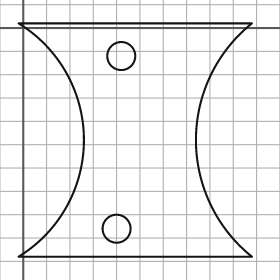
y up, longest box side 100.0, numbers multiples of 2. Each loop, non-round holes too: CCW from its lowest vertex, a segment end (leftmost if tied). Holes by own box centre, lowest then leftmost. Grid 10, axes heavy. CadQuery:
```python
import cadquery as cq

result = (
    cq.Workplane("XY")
    .moveTo(-2.0, -98.0)
    .lineTo(98.0, -98.0)
    .threePointArc((74.0, -48.0), (98.0, 2.0))
    .lineTo(-2.0, 2.0)
    .threePointArc((26.0, -48.0), (-2.0, -98.0))
    .close()
    .moveTo(40.0, -86.0)
    .circle(6.0)
    .moveTo(42.0, -12.0)
    .circle(6.0)
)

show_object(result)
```